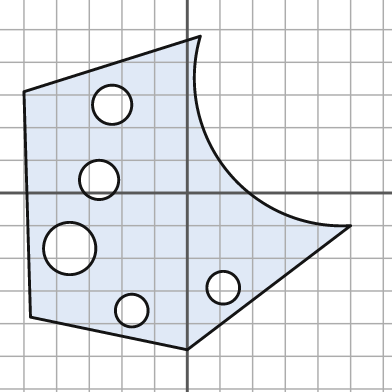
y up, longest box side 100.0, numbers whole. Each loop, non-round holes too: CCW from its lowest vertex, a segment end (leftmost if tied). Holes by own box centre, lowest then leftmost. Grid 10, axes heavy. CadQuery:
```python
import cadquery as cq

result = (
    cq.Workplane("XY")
    .moveTo(0.0, -48.0)
    .lineTo(50.0, -10.0)
    .threePointArc((12.0, 7.0), (4.0, 48.0))
    .lineTo(-50.0, 31.0)
    .lineTo(-48.0, -38.0)
    .close()
    .moveTo(-17.0, -36.0)
    .circle(5.0)
    .moveTo(11.0, -29.0)
    .circle(5.0)
    .moveTo(-36.0, -17.0)
    .circle(8.0)
    .moveTo(-27.0, 4.0)
    .circle(6.0)
    .moveTo(-23.0, 27.0)
    .circle(6.0)
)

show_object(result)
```